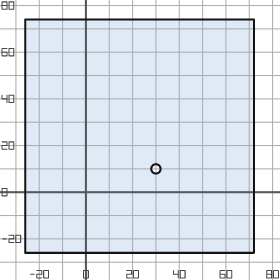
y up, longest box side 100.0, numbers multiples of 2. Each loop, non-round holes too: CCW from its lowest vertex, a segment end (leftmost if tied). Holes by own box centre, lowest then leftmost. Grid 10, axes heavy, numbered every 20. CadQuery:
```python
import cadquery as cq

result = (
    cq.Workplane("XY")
    .moveTo(-26.0, -26.0)
    .lineTo(72.0, -26.0)
    .lineTo(72.0, 74.0)
    .lineTo(-26.0, 74.0)
    .close()
    .moveTo(30.0, 10.0)
    .circle(2.0)
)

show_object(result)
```